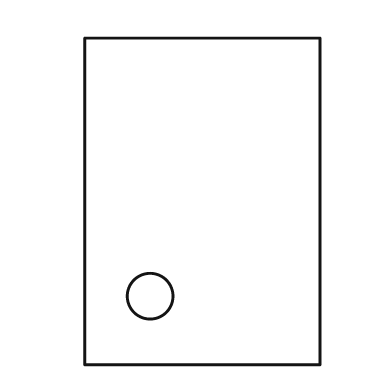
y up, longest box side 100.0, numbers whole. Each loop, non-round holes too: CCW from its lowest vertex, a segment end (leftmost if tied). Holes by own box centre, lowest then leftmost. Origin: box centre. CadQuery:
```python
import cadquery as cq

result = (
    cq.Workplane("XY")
    .moveTo(-36.0, -50.0)
    .lineTo(36.0, -50.0)
    .lineTo(36.0, 50.0)
    .lineTo(-36.0, 50.0)
    .close()
    .moveTo(-16.0, -29.0)
    .circle(7.0)
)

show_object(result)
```